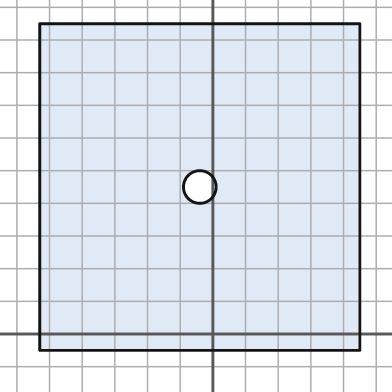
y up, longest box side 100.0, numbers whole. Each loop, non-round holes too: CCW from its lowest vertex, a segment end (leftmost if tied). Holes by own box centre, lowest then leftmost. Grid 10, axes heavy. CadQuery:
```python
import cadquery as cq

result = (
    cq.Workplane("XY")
    .moveTo(-53.0, -5.0)
    .lineTo(45.0, -5.0)
    .lineTo(45.0, 95.0)
    .lineTo(-53.0, 95.0)
    .close()
    .moveTo(-4.0, 45.0)
    .circle(5.0)
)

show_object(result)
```